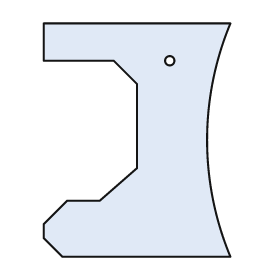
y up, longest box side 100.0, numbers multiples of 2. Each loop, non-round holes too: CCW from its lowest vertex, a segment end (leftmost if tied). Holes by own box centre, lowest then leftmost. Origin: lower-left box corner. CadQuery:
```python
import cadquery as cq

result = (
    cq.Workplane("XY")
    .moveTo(8.0, 0.0)
    .lineTo(80.0, 0.0)
    .threePointArc((70.0, 50.0), (80.0, 100.0))
    .lineTo(0.0, 100.0)
    .lineTo(0.0, 84.0)
    .lineTo(30.0, 84.0)
    .lineTo(40.0, 74.0)
    .lineTo(40.0, 38.0)
    .lineTo(24.0, 24.0)
    .lineTo(10.0, 24.0)
    .lineTo(0.0, 14.0)
    .lineTo(0.0, 8.0)
    .close()
    .moveTo(54.0, 84.0)
    .circle(2.0)
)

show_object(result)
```